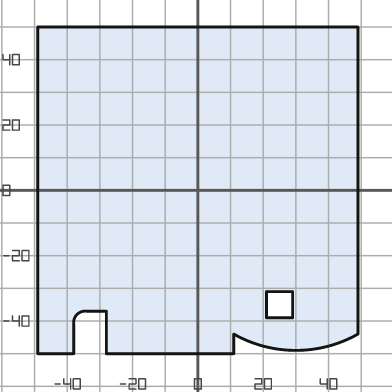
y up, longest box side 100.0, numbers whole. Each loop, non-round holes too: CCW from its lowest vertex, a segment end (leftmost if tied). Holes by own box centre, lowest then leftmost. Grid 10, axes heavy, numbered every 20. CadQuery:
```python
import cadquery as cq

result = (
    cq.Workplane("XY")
    .moveTo(-49.0, -50.0)
    .lineTo(-38.0, -50.0)
    .lineTo(-38.0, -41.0)
    .threePointArc((-37.0, -38.0), (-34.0, -37.0))
    .lineTo(-28.0, -37.0)
    .lineTo(-28.0, -50.0)
    .lineTo(11.0, -50.0)
    .lineTo(11.0, -44.0)
    .threePointArc((30.0, -49.0), (49.0, -44.0))
    .lineTo(49.0, 50.0)
    .lineTo(-49.0, 50.0)
    .close()
    .moveTo(21.0, -39.0)
    .lineTo(29.0, -39.0)
    .lineTo(29.0, -31.0)
    .lineTo(21.0, -31.0)
    .close()
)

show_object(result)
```